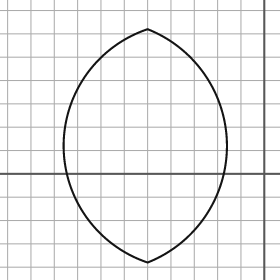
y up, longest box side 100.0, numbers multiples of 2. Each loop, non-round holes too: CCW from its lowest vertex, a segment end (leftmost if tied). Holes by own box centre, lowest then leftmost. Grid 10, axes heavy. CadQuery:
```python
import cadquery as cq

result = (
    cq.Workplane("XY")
    .moveTo(-50.0, -38.0)
    .threePointArc((-16.0, 12.0), (-50.0, 62.0))
    .threePointArc((-86.0, 12.0), (-50.0, -38.0))
    .close()
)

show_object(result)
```